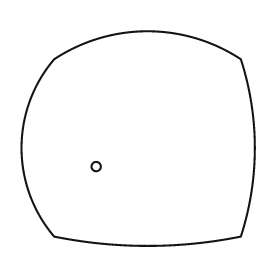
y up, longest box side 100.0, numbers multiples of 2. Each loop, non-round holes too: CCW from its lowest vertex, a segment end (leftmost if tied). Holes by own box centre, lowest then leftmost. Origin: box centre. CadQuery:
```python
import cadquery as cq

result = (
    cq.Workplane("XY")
    .moveTo(-36.0, -42.0)
    .threePointArc((4.0, -46.0), (44.0, -42.0))
    .threePointArc((50.0, -4.0), (44.0, 34.0))
    .threePointArc((4.0, 46.0), (-36.0, 34.0))
    .threePointArc((-50.0, -4.0), (-36.0, -42.0))
    .close()
    .moveTo(-18.0, -12.0)
    .circle(2.0)
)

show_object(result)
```